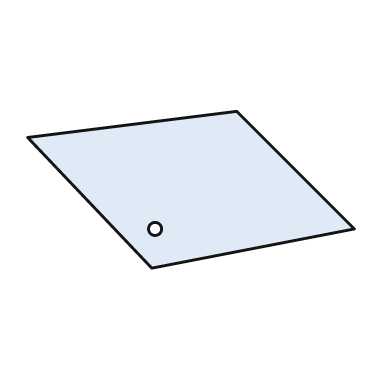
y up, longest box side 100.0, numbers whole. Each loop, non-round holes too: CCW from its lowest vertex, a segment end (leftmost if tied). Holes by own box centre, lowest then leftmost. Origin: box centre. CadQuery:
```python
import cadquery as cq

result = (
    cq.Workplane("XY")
    .moveTo(-12.0, -24.0)
    .lineTo(50.0, -12.0)
    .lineTo(14.0, 24.0)
    .lineTo(-50.0, 16.0)
    .close()
    .moveTo(-11.0, -12.0)
    .circle(2.0)
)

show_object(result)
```